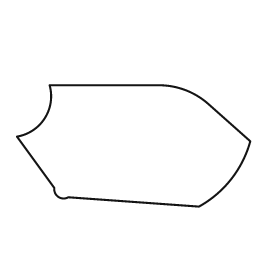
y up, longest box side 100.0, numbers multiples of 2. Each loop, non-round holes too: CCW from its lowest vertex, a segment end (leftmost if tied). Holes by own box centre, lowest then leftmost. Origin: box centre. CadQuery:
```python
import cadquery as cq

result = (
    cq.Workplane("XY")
    .moveTo(28.0, -26.0)
    .threePointArc((42.0, -14.0), (50.0, 2.0))
    .lineTo(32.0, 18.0)
    .threePointArc((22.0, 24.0), (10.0, 26.0))
    .lineTo(-36.0, 26.0)
    .threePointArc((-38.0, 12.0), (-50.0, 4.0))
    .lineTo(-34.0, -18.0)
    .threePointArc((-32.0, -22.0), (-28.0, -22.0))
    .close()
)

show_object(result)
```